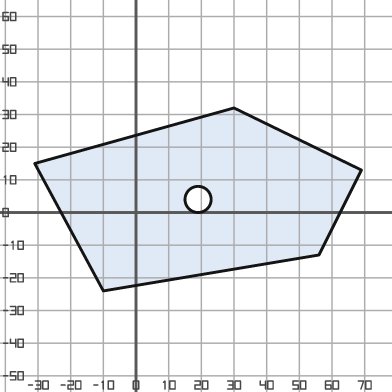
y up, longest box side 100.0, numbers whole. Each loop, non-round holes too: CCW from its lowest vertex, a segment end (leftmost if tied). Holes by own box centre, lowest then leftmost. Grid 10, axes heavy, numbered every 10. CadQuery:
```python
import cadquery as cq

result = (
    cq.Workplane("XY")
    .moveTo(-10.0, -24.0)
    .lineTo(56.0, -13.0)
    .lineTo(69.0, 13.0)
    .lineTo(30.0, 32.0)
    .lineTo(-31.0, 15.0)
    .close()
    .moveTo(19.0, 4.0)
    .circle(4.0)
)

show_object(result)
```